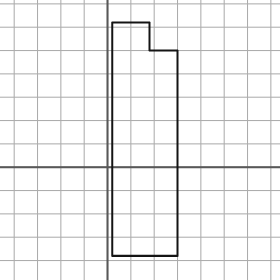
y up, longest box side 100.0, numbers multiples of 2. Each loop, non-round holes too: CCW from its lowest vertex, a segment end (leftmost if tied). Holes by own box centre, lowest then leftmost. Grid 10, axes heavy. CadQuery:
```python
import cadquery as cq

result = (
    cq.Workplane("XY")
    .moveTo(2.0, -38.0)
    .lineTo(30.0, -38.0)
    .lineTo(30.0, 50.0)
    .lineTo(18.0, 50.0)
    .lineTo(18.0, 62.0)
    .lineTo(2.0, 62.0)
    .close()
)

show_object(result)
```